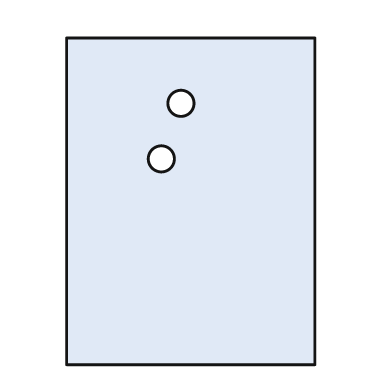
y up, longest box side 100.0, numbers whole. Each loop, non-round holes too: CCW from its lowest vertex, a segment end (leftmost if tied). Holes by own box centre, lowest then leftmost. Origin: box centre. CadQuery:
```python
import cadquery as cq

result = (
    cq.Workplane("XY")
    .moveTo(-38.0, -50.0)
    .lineTo(38.0, -50.0)
    .lineTo(38.0, 50.0)
    .lineTo(-38.0, 50.0)
    .close()
    .moveTo(-9.0, 13.0)
    .circle(4.0)
    .moveTo(-3.0, 30.0)
    .circle(4.0)
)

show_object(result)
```